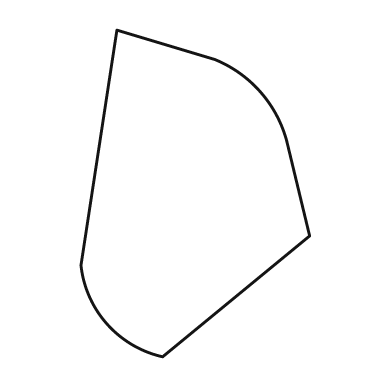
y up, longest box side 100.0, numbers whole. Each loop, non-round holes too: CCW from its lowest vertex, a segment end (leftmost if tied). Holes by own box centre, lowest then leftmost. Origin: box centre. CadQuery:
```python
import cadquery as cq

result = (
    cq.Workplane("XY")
    .moveTo(-10.0, -50.0)
    .lineTo(35.0, -13.0)
    .lineTo(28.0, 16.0)
    .threePointArc((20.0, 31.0), (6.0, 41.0))
    .lineTo(-24.0, 50.0)
    .lineTo(-35.0, -22.0)
    .threePointArc((-27.0, -40.0), (-10.0, -50.0))
    .close()
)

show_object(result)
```